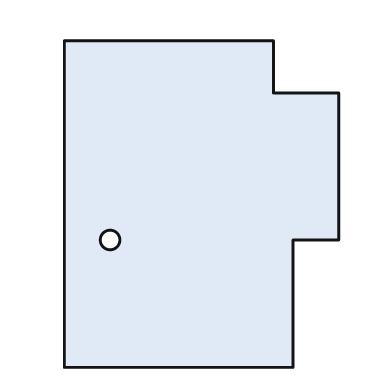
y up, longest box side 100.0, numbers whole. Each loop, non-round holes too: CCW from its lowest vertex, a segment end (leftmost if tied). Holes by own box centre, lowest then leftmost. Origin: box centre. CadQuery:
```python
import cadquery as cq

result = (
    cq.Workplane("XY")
    .moveTo(-42.0, -50.0)
    .lineTo(28.0, -50.0)
    .lineTo(28.0, -11.0)
    .lineTo(42.0, -11.0)
    .lineTo(42.0, 34.0)
    .lineTo(22.0, 34.0)
    .lineTo(22.0, 50.0)
    .lineTo(-42.0, 50.0)
    .close()
    .moveTo(-28.0, -11.0)
    .circle(3.0)
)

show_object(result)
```